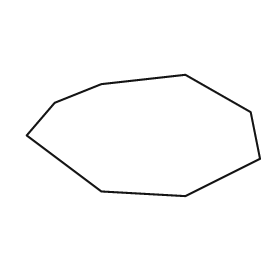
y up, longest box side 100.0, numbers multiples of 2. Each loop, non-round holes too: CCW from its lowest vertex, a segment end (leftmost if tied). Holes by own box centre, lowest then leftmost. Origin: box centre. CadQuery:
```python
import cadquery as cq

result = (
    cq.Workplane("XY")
    .moveTo(18.0, -26.0)
    .lineTo(50.0, -10.0)
    .lineTo(46.0, 10.0)
    .lineTo(18.0, 26.0)
    .lineTo(-18.0, 22.0)
    .lineTo(-38.0, 14.0)
    .lineTo(-50.0, 0.0)
    .lineTo(-18.0, -24.0)
    .close()
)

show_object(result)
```